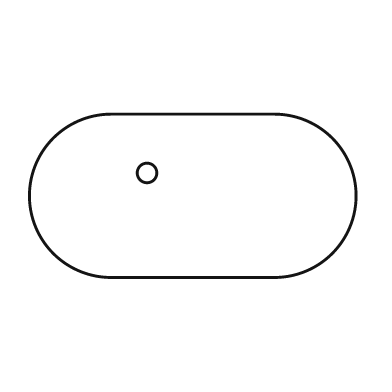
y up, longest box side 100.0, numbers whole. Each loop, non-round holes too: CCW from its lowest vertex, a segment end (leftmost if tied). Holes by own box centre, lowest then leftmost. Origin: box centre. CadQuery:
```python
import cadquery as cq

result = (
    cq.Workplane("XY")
    .moveTo(-25.0, -25.0)
    .lineTo(25.0, -25.0)
    .threePointArc((50.0, 0.0), (25.0, 25.0))
    .lineTo(-25.0, 25.0)
    .threePointArc((-50.0, 0.0), (-25.0, -25.0))
    .close()
    .moveTo(-14.0, 7.0)
    .circle(3.0)
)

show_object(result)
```